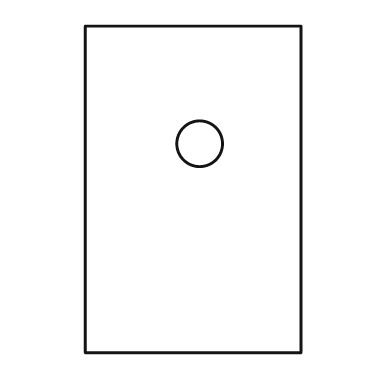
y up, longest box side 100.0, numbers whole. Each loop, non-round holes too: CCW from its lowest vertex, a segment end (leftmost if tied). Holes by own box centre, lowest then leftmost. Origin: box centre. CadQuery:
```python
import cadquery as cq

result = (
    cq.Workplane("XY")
    .moveTo(-33.0, -50.0)
    .lineTo(33.0, -50.0)
    .lineTo(33.0, 50.0)
    .lineTo(-33.0, 50.0)
    .close()
    .moveTo(2.0, 14.0)
    .circle(7.0)
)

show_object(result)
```